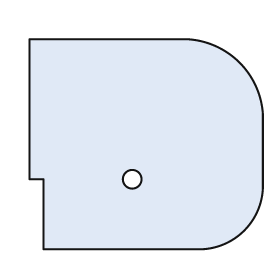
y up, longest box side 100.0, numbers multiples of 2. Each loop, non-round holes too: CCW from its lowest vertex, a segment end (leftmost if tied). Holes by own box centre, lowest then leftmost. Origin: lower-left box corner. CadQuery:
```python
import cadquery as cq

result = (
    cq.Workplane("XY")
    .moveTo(6.0, 0.0)
    .lineTo(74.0, 0.0)
    .threePointArc((92.0, 8.0), (100.0, 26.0))
    .lineTo(100.0, 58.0)
    .threePointArc((90.0, 80.0), (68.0, 90.0))
    .lineTo(0.0, 90.0)
    .lineTo(0.0, 30.0)
    .lineTo(6.0, 30.0)
    .close()
    .moveTo(44.0, 30.0)
    .circle(4.0)
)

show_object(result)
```